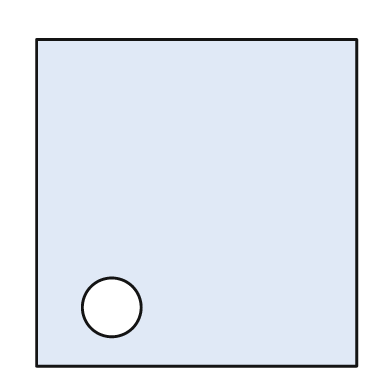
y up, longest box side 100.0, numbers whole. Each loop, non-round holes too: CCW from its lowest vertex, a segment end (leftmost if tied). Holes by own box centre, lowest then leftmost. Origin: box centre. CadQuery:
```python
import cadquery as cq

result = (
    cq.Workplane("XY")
    .moveTo(-49.0, -50.0)
    .lineTo(49.0, -50.0)
    .lineTo(49.0, 50.0)
    .lineTo(-49.0, 50.0)
    .close()
    .moveTo(-26.0, -32.0)
    .circle(9.0)
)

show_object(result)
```